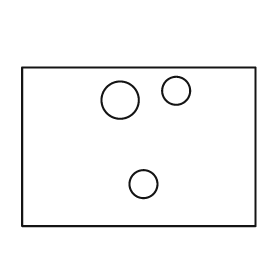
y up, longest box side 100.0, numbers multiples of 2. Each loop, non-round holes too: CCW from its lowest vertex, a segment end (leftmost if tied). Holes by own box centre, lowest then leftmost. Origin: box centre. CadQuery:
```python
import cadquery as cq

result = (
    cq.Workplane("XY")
    .moveTo(-50.0, -34.0)
    .lineTo(50.0, -34.0)
    .lineTo(50.0, 34.0)
    .lineTo(-50.0, 34.0)
    .close()
    .moveTo(2.0, -16.0)
    .circle(6.0)
    .moveTo(-8.0, 20.0)
    .circle(8.0)
    .moveTo(16.0, 24.0)
    .circle(6.0)
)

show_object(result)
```